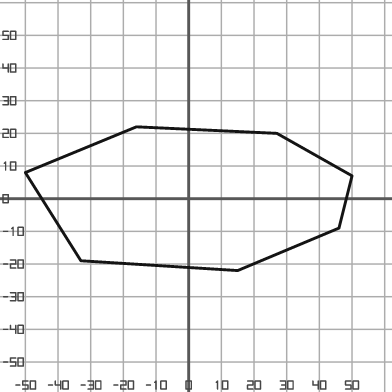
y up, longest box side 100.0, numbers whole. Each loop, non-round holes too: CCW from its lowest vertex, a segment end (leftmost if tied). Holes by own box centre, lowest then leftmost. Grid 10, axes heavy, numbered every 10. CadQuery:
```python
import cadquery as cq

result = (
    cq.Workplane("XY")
    .moveTo(15.0, -22.0)
    .lineTo(46.0, -9.0)
    .lineTo(50.0, 7.0)
    .lineTo(27.0, 20.0)
    .lineTo(-16.0, 22.0)
    .lineTo(-50.0, 8.0)
    .lineTo(-33.0, -19.0)
    .close()
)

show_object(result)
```